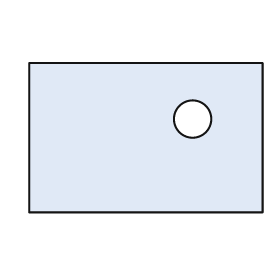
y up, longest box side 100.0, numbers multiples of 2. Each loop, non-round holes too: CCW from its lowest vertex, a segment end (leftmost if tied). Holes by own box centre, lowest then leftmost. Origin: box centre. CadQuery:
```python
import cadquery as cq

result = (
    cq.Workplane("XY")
    .moveTo(-50.0, -32.0)
    .lineTo(50.0, -32.0)
    .lineTo(50.0, 32.0)
    .lineTo(-50.0, 32.0)
    .close()
    .moveTo(20.0, 8.0)
    .circle(8.0)
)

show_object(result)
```